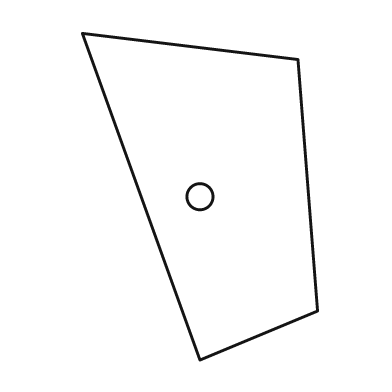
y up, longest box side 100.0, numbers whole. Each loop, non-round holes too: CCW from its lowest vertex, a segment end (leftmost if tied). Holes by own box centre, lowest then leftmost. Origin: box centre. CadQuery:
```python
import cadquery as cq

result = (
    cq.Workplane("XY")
    .moveTo(0.0, -50.0)
    .lineTo(36.0, -35.0)
    .lineTo(30.0, 42.0)
    .lineTo(-36.0, 50.0)
    .close()
    .moveTo(0.0, 0.0)
    .circle(4.0)
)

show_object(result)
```